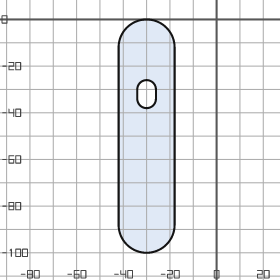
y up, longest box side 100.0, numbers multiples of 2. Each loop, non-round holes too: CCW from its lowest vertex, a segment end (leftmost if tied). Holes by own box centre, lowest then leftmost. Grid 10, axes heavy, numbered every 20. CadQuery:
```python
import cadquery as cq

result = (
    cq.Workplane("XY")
    .moveTo(-42.0, -88.0)
    .threePointArc((-30.0, -100.0), (-18.0, -88.0))
    .lineTo(-18.0, -12.0)
    .threePointArc((-30.0, 0.0), (-42.0, -12.0))
    .close()
    .moveTo(-34.0, -34.0)
    .threePointArc((-30.0, -38.0), (-26.0, -34.0))
    .lineTo(-26.0, -30.0)
    .threePointArc((-30.0, -26.0), (-34.0, -30.0))
    .close()
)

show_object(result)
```